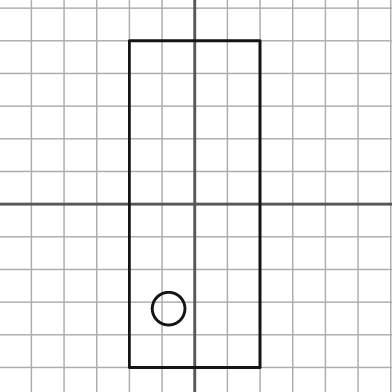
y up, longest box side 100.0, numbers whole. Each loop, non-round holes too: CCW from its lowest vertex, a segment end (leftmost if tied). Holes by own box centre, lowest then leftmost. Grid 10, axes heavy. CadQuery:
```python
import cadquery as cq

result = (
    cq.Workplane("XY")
    .moveTo(-20.0, -50.0)
    .lineTo(20.0, -50.0)
    .lineTo(20.0, 50.0)
    .lineTo(-20.0, 50.0)
    .close()
    .moveTo(-8.0, -32.0)
    .circle(5.0)
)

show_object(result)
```